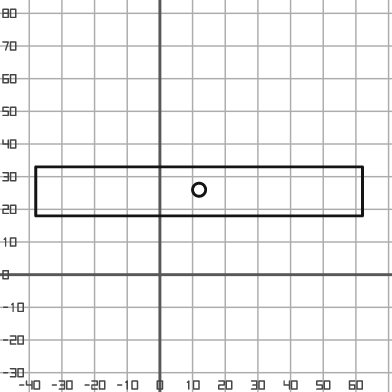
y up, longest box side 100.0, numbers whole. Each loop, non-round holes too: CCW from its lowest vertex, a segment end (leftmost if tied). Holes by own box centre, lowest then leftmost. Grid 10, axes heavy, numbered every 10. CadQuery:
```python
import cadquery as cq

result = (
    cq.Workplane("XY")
    .moveTo(-38.0, 18.0)
    .lineTo(62.0, 18.0)
    .lineTo(62.0, 33.0)
    .lineTo(-38.0, 33.0)
    .close()
    .moveTo(12.0, 26.0)
    .circle(2.0)
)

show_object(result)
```